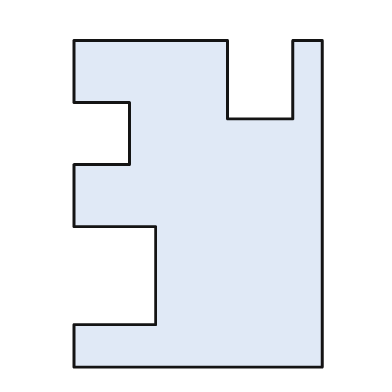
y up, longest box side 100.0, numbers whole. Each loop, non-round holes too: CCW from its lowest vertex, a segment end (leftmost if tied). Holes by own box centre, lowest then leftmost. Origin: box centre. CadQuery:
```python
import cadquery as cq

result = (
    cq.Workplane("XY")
    .moveTo(-38.0, -50.0)
    .lineTo(38.0, -50.0)
    .lineTo(38.0, 50.0)
    .lineTo(29.0, 50.0)
    .lineTo(29.0, 26.0)
    .lineTo(9.0, 26.0)
    .lineTo(9.0, 50.0)
    .lineTo(-38.0, 50.0)
    .lineTo(-38.0, 31.0)
    .lineTo(-21.0, 31.0)
    .lineTo(-21.0, 12.0)
    .lineTo(-38.0, 12.0)
    .lineTo(-38.0, -7.0)
    .lineTo(-13.0, -7.0)
    .lineTo(-13.0, -37.0)
    .lineTo(-38.0, -37.0)
    .close()
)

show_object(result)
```